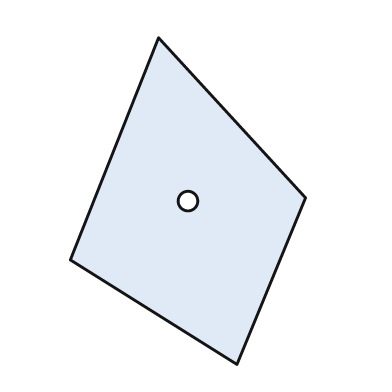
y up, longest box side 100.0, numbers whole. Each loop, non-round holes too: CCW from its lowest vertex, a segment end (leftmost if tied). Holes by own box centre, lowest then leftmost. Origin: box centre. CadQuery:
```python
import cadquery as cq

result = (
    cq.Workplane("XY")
    .moveTo(15.0, -50.0)
    .lineTo(36.0, 1.0)
    .lineTo(-9.0, 50.0)
    .lineTo(-36.0, -18.0)
    .close()
    .moveTo(0.0, 0.0)
    .circle(3.0)
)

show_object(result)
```